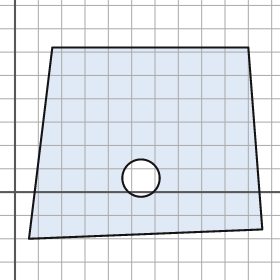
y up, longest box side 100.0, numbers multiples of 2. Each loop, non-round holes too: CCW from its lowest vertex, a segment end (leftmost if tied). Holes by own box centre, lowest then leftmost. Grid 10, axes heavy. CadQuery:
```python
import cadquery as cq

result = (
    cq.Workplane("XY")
    .moveTo(6.0, -20.0)
    .lineTo(106.0, -16.0)
    .lineTo(100.0, 62.0)
    .lineTo(16.0, 62.0)
    .close()
    .moveTo(54.0, 6.0)
    .circle(8.0)
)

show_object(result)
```